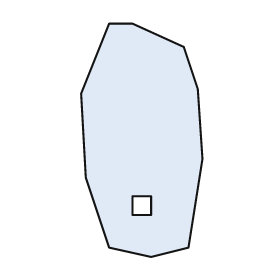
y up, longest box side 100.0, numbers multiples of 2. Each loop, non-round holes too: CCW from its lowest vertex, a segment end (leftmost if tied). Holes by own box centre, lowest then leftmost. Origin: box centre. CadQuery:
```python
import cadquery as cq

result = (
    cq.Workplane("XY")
    .moveTo(4.0, -50.0)
    .lineTo(20.0, -46.0)
    .lineTo(26.0, -8.0)
    .lineTo(24.0, 22.0)
    .lineTo(18.0, 40.0)
    .lineTo(-4.0, 50.0)
    .lineTo(-14.0, 50.0)
    .lineTo(-26.0, 20.0)
    .lineTo(-24.0, -16.0)
    .lineTo(-14.0, -46.0)
    .close()
    .moveTo(-4.0, -32.0)
    .lineTo(4.0, -32.0)
    .lineTo(4.0, -24.0)
    .lineTo(-4.0, -24.0)
    .close()
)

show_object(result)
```